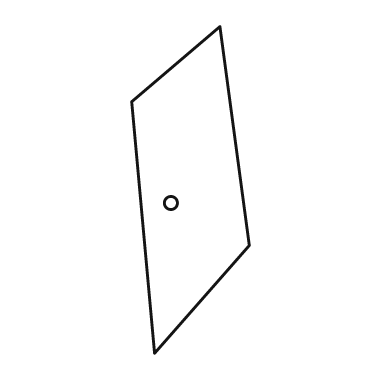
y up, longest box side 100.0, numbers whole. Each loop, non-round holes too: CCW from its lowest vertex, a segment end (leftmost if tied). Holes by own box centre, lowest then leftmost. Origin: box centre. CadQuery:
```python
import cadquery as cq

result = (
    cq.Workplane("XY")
    .moveTo(-11.0, -50.0)
    .lineTo(18.0, -17.0)
    .lineTo(9.0, 50.0)
    .lineTo(-18.0, 27.0)
    .close()
    .moveTo(-6.0, -4.0)
    .circle(2.0)
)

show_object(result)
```